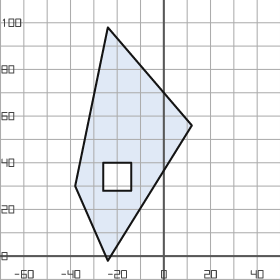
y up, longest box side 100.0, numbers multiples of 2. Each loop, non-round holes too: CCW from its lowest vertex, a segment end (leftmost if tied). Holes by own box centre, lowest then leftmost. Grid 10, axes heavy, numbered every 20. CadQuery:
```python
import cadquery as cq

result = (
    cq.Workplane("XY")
    .moveTo(-24.0, -2.0)
    .lineTo(12.0, 56.0)
    .lineTo(-24.0, 98.0)
    .lineTo(-38.0, 30.0)
    .close()
    .moveTo(-26.0, 28.0)
    .lineTo(-14.0, 28.0)
    .lineTo(-14.0, 40.0)
    .lineTo(-26.0, 40.0)
    .close()
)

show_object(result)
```